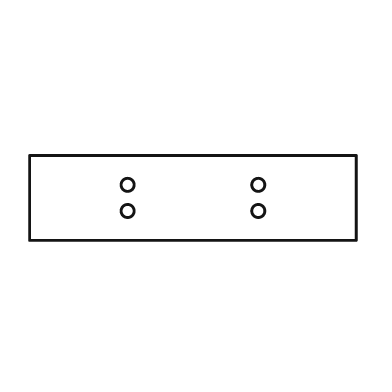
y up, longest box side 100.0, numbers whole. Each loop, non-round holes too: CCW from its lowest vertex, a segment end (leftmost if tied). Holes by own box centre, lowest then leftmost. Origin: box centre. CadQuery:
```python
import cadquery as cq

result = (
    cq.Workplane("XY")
    .moveTo(-50.0, -13.0)
    .lineTo(50.0, -13.0)
    .lineTo(50.0, 13.0)
    .lineTo(-50.0, 13.0)
    .close()
    .moveTo(-20.0, -4.0)
    .circle(2.0)
    .moveTo(20.0, -4.0)
    .circle(2.0)
    .moveTo(-20.0, 4.0)
    .circle(2.0)
    .moveTo(20.0, 4.0)
    .circle(2.0)
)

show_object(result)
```